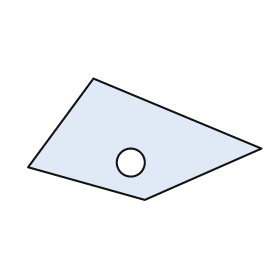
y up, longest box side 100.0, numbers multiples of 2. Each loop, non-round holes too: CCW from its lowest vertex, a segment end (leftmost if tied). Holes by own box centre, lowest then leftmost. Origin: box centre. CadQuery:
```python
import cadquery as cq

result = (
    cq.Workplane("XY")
    .moveTo(0.0, -26.0)
    .lineTo(50.0, -4.0)
    .lineTo(-22.0, 26.0)
    .lineTo(-50.0, -12.0)
    .close()
    .moveTo(-6.0, -10.0)
    .circle(6.0)
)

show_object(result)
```